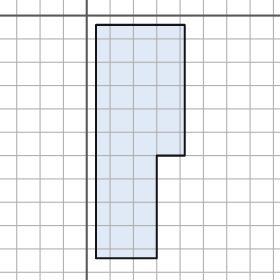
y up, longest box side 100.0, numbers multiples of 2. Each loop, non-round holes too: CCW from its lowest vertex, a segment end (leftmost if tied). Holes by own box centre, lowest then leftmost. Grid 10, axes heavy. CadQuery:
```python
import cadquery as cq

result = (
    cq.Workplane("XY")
    .moveTo(4.0, -104.0)
    .lineTo(30.0, -104.0)
    .lineTo(30.0, -60.0)
    .lineTo(42.0, -60.0)
    .lineTo(42.0, -4.0)
    .lineTo(4.0, -4.0)
    .close()
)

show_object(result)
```